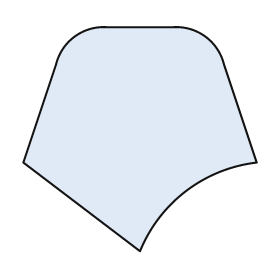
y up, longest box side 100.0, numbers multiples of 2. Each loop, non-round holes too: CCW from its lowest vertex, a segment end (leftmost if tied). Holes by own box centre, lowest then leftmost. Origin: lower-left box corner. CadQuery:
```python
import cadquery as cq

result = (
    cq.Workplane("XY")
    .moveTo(50.0, 0.0)
    .threePointArc((70.0, 26.0), (100.0, 38.0))
    .lineTo(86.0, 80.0)
    .threePointArc((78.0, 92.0), (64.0, 96.0))
    .lineTo(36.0, 96.0)
    .threePointArc((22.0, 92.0), (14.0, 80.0))
    .lineTo(0.0, 38.0)
    .close()
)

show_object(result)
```